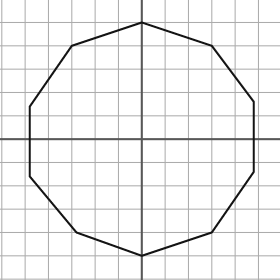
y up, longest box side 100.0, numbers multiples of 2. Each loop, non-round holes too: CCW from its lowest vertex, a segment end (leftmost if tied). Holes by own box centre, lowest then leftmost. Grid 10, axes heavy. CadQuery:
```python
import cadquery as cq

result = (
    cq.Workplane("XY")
    .moveTo(0.0, -50.0)
    .lineTo(30.0, -40.0)
    .lineTo(48.0, -14.0)
    .lineTo(48.0, 16.0)
    .lineTo(30.0, 40.0)
    .lineTo(0.0, 50.0)
    .lineTo(-30.0, 40.0)
    .lineTo(-48.0, 14.0)
    .lineTo(-48.0, -16.0)
    .lineTo(-28.0, -40.0)
    .close()
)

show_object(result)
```